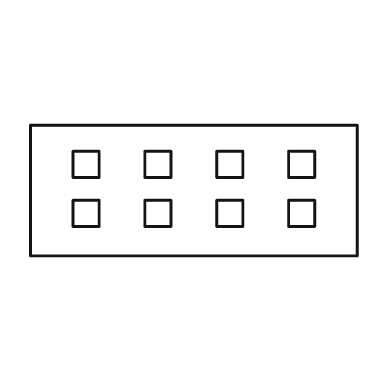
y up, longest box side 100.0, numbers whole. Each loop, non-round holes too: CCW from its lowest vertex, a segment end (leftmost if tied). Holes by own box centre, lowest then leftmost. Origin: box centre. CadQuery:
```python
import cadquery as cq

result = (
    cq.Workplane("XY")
    .moveTo(-50.0, -20.0)
    .lineTo(50.0, -20.0)
    .lineTo(50.0, 20.0)
    .lineTo(-50.0, 20.0)
    .close()
    .moveTo(-37.0, -11.0)
    .lineTo(-29.0, -11.0)
    .lineTo(-29.0, -3.0)
    .lineTo(-37.0, -3.0)
    .close()
    .moveTo(-15.0, -11.0)
    .lineTo(-7.0, -11.0)
    .lineTo(-7.0, -3.0)
    .lineTo(-15.0, -3.0)
    .close()
    .moveTo(7.0, -11.0)
    .lineTo(15.0, -11.0)
    .lineTo(15.0, -3.0)
    .lineTo(7.0, -3.0)
    .close()
    .moveTo(29.0, -11.0)
    .lineTo(37.0, -11.0)
    .lineTo(37.0, -3.0)
    .lineTo(29.0, -3.0)
    .close()
    .moveTo(-37.0, 4.0)
    .lineTo(-29.0, 4.0)
    .lineTo(-29.0, 12.0)
    .lineTo(-37.0, 12.0)
    .close()
    .moveTo(-15.0, 4.0)
    .lineTo(-7.0, 4.0)
    .lineTo(-7.0, 12.0)
    .lineTo(-15.0, 12.0)
    .close()
    .moveTo(7.0, 4.0)
    .lineTo(15.0, 4.0)
    .lineTo(15.0, 12.0)
    .lineTo(7.0, 12.0)
    .close()
    .moveTo(29.0, 4.0)
    .lineTo(37.0, 4.0)
    .lineTo(37.0, 12.0)
    .lineTo(29.0, 12.0)
    .close()
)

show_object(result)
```